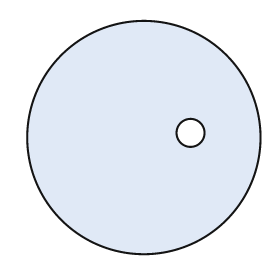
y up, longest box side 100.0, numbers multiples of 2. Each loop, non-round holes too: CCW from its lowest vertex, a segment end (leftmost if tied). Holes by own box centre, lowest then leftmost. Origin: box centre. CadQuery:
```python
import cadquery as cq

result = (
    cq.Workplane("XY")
    .moveTo(0.0, 0.0)
    .circle(50.0)
    .moveTo(20.0, 2.0)
    .circle(6.0)
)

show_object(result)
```